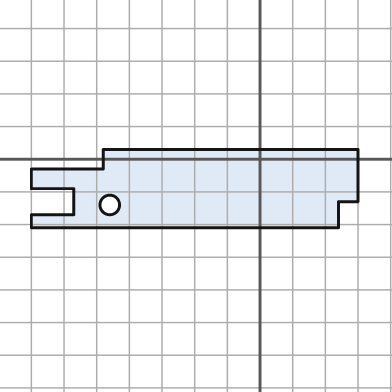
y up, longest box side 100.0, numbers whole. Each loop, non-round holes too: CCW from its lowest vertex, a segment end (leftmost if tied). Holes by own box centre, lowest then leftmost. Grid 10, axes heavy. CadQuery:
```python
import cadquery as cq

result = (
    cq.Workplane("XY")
    .moveTo(-70.0, -21.0)
    .lineTo(24.0, -21.0)
    .lineTo(24.0, -13.0)
    .lineTo(30.0, -13.0)
    .lineTo(30.0, 3.0)
    .lineTo(-48.0, 3.0)
    .lineTo(-48.0, -3.0)
    .lineTo(-70.0, -3.0)
    .lineTo(-70.0, -9.0)
    .lineTo(-57.0, -9.0)
    .lineTo(-57.0, -17.0)
    .lineTo(-70.0, -17.0)
    .close()
    .moveTo(-46.0, -14.0)
    .circle(3.0)
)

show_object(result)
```